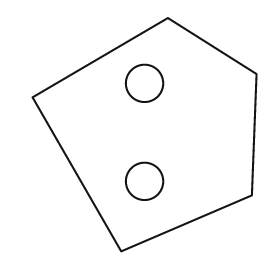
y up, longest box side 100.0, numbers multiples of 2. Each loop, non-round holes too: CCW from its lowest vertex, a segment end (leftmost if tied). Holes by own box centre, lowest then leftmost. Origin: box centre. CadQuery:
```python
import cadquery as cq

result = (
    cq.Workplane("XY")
    .moveTo(-10.0, -50.0)
    .lineTo(46.0, -26.0)
    .lineTo(48.0, 26.0)
    .lineTo(10.0, 50.0)
    .lineTo(-48.0, 16.0)
    .close()
    .moveTo(0.0, -20.0)
    .circle(8.0)
    .moveTo(0.0, 22.0)
    .circle(8.0)
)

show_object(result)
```